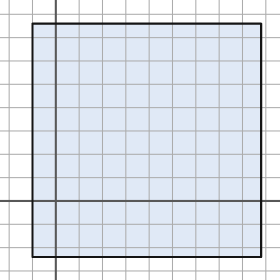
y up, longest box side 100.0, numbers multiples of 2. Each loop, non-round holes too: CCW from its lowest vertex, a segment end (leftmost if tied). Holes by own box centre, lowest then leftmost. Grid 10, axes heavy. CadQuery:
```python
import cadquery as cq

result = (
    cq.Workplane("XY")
    .moveTo(-10.0, -24.0)
    .lineTo(88.0, -24.0)
    .lineTo(88.0, 76.0)
    .lineTo(-10.0, 76.0)
    .close()
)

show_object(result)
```